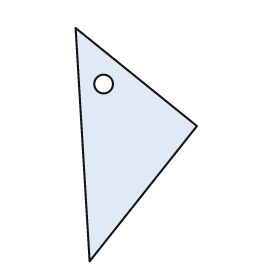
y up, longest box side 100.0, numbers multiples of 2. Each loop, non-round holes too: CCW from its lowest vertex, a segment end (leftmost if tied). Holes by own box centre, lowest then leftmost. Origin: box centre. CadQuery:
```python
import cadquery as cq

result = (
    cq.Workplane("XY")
    .moveTo(-20.0, -50.0)
    .lineTo(26.0, 8.0)
    .lineTo(-26.0, 50.0)
    .close()
    .moveTo(-14.0, 26.0)
    .circle(4.0)
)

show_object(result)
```